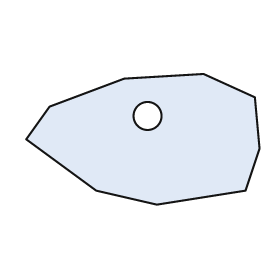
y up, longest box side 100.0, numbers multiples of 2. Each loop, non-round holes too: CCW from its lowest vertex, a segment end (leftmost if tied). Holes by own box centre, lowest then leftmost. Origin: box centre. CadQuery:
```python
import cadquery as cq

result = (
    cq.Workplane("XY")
    .moveTo(6.0, -28.0)
    .lineTo(44.0, -22.0)
    .lineTo(50.0, -4.0)
    .lineTo(48.0, 18.0)
    .lineTo(26.0, 28.0)
    .lineTo(-8.0, 26.0)
    .lineTo(-40.0, 14.0)
    .lineTo(-50.0, 0.0)
    .lineTo(-20.0, -22.0)
    .close()
    .moveTo(2.0, 10.0)
    .circle(6.0)
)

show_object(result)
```